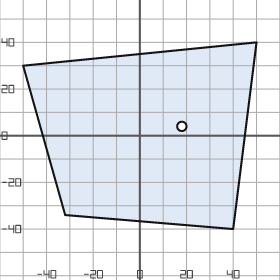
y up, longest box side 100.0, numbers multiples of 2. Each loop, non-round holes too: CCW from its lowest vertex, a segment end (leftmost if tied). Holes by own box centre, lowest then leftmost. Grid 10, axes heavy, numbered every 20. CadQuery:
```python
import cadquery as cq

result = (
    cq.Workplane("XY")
    .moveTo(40.0, -40.0)
    .lineTo(50.0, 40.0)
    .lineTo(-50.0, 30.0)
    .lineTo(-32.0, -34.0)
    .close()
    .moveTo(18.0, 4.0)
    .circle(2.0)
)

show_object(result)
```